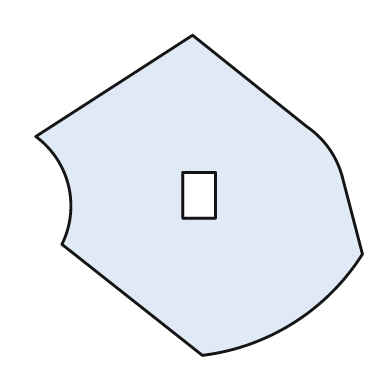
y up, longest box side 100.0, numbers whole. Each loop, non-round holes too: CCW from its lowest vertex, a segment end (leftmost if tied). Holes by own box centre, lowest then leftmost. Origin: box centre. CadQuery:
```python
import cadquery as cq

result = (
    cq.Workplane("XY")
    .moveTo(1.0, -49.0)
    .threePointArc((29.0, -39.0), (50.0, -18.0))
    .lineTo(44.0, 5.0)
    .threePointArc((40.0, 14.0), (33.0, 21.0))
    .lineTo(-2.0, 49.0)
    .lineTo(-50.0, 18.0)
    .threePointArc((-40.0, 3.0), (-42.0, -15.0))
    .close()
    .moveTo(-5.0, -7.0)
    .lineTo(5.0, -7.0)
    .lineTo(5.0, 7.0)
    .lineTo(-5.0, 7.0)
    .close()
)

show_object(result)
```